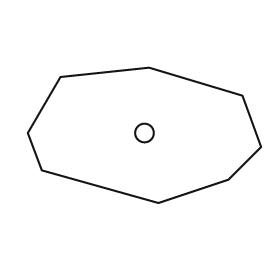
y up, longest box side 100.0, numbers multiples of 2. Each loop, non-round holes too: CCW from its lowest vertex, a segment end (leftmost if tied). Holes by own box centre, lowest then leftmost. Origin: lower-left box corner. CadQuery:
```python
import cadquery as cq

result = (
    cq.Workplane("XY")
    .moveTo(56.0, 0.0)
    .lineTo(86.0, 10.0)
    .lineTo(100.0, 24.0)
    .lineTo(92.0, 46.0)
    .lineTo(52.0, 58.0)
    .lineTo(14.0, 54.0)
    .lineTo(0.0, 30.0)
    .lineTo(6.0, 14.0)
    .close()
    .moveTo(50.0, 30.0)
    .circle(4.0)
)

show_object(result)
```